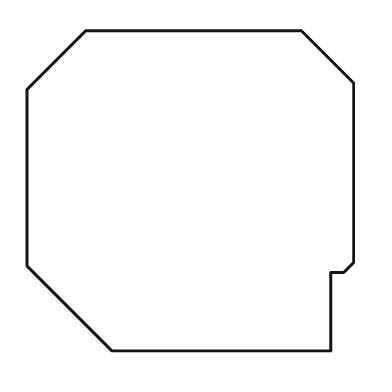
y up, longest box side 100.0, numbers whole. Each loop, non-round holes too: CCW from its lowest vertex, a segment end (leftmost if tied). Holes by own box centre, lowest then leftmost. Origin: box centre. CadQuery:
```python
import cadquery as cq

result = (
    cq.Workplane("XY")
    .moveTo(-24.0, -49.0)
    .lineTo(43.0, -49.0)
    .lineTo(43.0, -25.0)
    .lineTo(47.0, -25.0)
    .lineTo(50.0, -22.0)
    .lineTo(50.0, 33.0)
    .lineTo(34.0, 49.0)
    .lineTo(-32.0, 49.0)
    .lineTo(-50.0, 31.0)
    .lineTo(-50.0, -23.0)
    .close()
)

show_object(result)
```